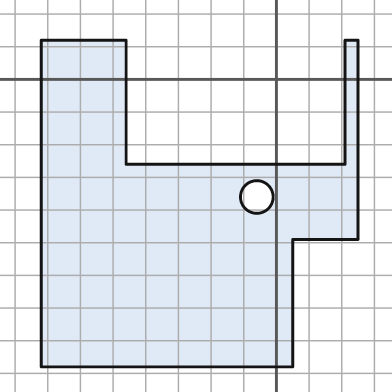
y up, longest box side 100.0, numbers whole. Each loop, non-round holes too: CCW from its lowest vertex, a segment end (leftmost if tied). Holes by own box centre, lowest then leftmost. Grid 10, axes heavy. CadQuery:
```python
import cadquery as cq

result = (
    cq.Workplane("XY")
    .moveTo(-72.0, -88.0)
    .lineTo(5.0, -88.0)
    .lineTo(5.0, -49.0)
    .lineTo(25.0, -49.0)
    .lineTo(25.0, 12.0)
    .lineTo(21.0, 12.0)
    .lineTo(21.0, -26.0)
    .lineTo(-46.0, -26.0)
    .lineTo(-46.0, 12.0)
    .lineTo(-72.0, 12.0)
    .close()
    .moveTo(-6.0, -36.0)
    .circle(5.0)
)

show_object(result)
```